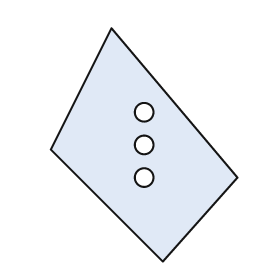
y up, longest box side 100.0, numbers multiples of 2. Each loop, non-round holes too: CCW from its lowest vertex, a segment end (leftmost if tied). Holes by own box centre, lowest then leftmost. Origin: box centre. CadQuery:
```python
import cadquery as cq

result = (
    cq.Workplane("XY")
    .moveTo(8.0, -50.0)
    .lineTo(40.0, -14.0)
    .lineTo(-14.0, 50.0)
    .lineTo(-40.0, -2.0)
    .close()
    .moveTo(0.0, -14.0)
    .circle(4.0)
    .moveTo(0.0, 0.0)
    .circle(4.0)
    .moveTo(0.0, 14.0)
    .circle(4.0)
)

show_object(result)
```